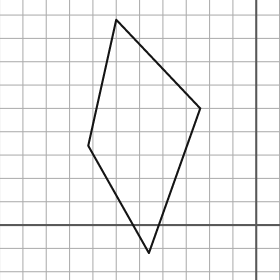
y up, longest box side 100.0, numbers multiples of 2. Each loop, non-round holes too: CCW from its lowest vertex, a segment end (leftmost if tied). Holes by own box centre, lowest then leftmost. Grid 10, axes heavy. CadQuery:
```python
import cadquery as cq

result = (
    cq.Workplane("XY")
    .moveTo(-46.0, -12.0)
    .lineTo(-24.0, 50.0)
    .lineTo(-60.0, 88.0)
    .lineTo(-72.0, 34.0)
    .close()
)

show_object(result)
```